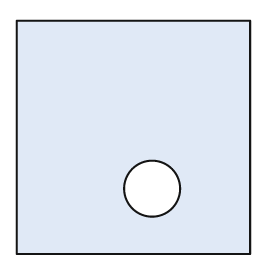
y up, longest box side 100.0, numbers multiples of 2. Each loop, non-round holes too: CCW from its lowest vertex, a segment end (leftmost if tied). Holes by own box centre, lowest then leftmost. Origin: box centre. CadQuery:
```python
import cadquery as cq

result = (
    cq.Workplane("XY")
    .moveTo(-50.0, -50.0)
    .lineTo(50.0, -50.0)
    .lineTo(50.0, 50.0)
    .lineTo(-50.0, 50.0)
    .close()
    .moveTo(8.0, -22.0)
    .circle(12.0)
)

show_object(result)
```